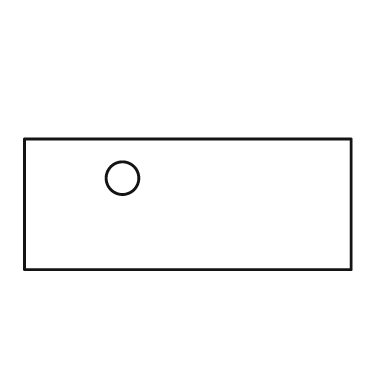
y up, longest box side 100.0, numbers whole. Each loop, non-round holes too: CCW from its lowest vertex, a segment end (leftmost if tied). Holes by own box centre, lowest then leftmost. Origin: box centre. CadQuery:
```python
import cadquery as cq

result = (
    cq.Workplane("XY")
    .moveTo(-50.0, -20.0)
    .lineTo(50.0, -20.0)
    .lineTo(50.0, 20.0)
    .lineTo(-50.0, 20.0)
    .close()
    .moveTo(-20.0, 8.0)
    .circle(5.0)
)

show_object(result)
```